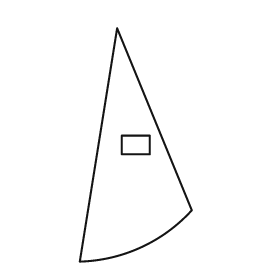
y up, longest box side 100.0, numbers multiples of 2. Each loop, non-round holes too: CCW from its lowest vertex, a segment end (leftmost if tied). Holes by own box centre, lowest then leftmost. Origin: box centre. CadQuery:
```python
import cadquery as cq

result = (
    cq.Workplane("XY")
    .moveTo(-24.0, -50.0)
    .threePointArc((2.0, -44.0), (24.0, -28.0))
    .lineTo(-8.0, 50.0)
    .close()
    .moveTo(-6.0, -4.0)
    .lineTo(6.0, -4.0)
    .lineTo(6.0, 4.0)
    .lineTo(-6.0, 4.0)
    .close()
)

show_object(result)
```